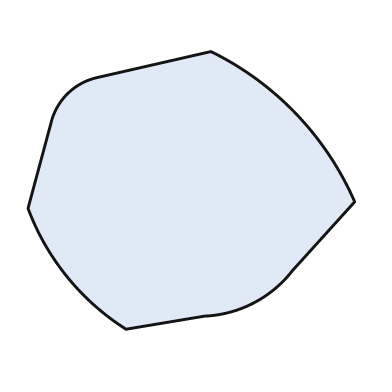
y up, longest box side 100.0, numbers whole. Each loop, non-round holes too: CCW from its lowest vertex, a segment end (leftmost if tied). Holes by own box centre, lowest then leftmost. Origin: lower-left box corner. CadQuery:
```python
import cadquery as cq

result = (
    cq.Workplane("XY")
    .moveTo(30.0, 0.0)
    .lineTo(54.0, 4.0)
    .threePointArc((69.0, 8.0), (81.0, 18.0))
    .lineTo(100.0, 39.0)
    .threePointArc((82.0, 66.0), (56.0, 85.0))
    .lineTo(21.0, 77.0)
    .threePointArc((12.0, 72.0), (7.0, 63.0))
    .lineTo(0.0, 37.0)
    .threePointArc((12.0, 16.0), (30.0, 0.0))
    .close()
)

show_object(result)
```